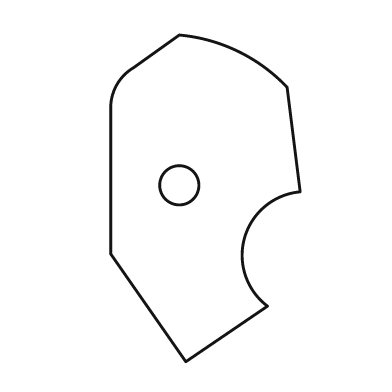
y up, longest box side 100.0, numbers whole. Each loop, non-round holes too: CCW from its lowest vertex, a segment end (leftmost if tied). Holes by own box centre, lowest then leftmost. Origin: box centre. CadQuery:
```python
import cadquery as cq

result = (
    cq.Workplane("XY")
    .moveTo(-6.0, -50.0)
    .lineTo(19.0, -33.0)
    .threePointArc((12.0, -12.0), (29.0, 2.0))
    .lineTo(25.0, 34.0)
    .threePointArc((10.0, 45.0), (-8.0, 50.0))
    .lineTo(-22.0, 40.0)
    .threePointArc((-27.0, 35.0), (-29.0, 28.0))
    .lineTo(-29.0, -17.0)
    .close()
    .moveTo(-8.0, 4.0)
    .circle(6.0)
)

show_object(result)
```